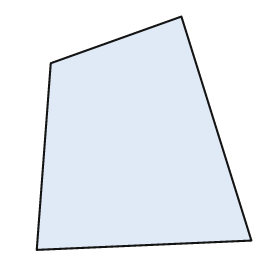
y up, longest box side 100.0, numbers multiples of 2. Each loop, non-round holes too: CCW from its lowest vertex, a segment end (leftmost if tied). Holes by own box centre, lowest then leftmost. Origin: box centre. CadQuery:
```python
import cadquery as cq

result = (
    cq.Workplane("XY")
    .moveTo(-46.0, -50.0)
    .lineTo(46.0, -46.0)
    .lineTo(16.0, 50.0)
    .lineTo(-40.0, 30.0)
    .close()
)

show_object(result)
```